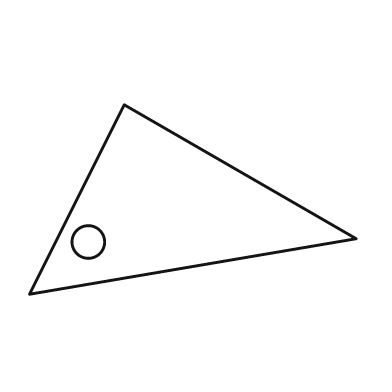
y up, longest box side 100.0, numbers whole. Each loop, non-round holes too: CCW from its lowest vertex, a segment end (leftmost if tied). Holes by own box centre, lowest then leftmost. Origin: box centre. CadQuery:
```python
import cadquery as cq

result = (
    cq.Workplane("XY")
    .moveTo(-50.0, -29.0)
    .lineTo(50.0, -12.0)
    .lineTo(-21.0, 29.0)
    .close()
    .moveTo(-32.0, -13.0)
    .circle(5.0)
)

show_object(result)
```